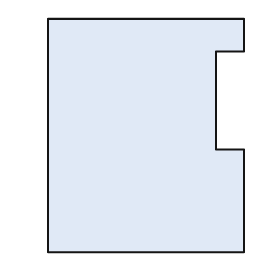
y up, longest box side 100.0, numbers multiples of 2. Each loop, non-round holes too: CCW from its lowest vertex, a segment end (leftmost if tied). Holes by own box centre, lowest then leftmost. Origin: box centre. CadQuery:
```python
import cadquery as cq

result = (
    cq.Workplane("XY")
    .moveTo(-42.0, -50.0)
    .lineTo(42.0, -50.0)
    .lineTo(42.0, -6.0)
    .lineTo(30.0, -6.0)
    .lineTo(30.0, 36.0)
    .lineTo(42.0, 36.0)
    .lineTo(42.0, 50.0)
    .lineTo(-42.0, 50.0)
    .close()
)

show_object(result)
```